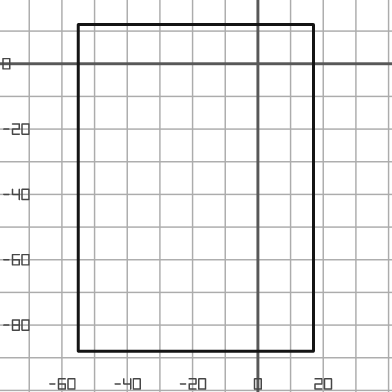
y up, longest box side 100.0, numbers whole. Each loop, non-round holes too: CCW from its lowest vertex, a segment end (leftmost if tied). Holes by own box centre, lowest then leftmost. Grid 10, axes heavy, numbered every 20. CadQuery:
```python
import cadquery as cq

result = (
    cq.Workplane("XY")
    .moveTo(-55.0, -88.0)
    .lineTo(17.0, -88.0)
    .lineTo(17.0, 12.0)
    .lineTo(-55.0, 12.0)
    .close()
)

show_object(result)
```